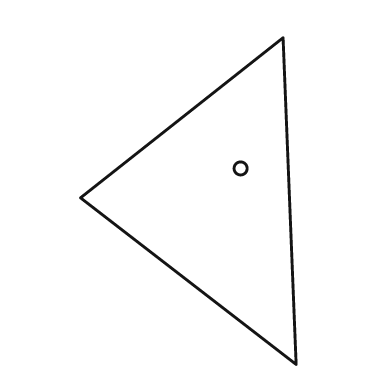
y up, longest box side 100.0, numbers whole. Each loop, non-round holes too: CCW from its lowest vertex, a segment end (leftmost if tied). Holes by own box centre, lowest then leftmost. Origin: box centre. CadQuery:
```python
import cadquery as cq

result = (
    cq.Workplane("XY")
    .moveTo(33.0, -50.0)
    .lineTo(29.0, 50.0)
    .lineTo(-33.0, 1.0)
    .close()
    .moveTo(16.0, 10.0)
    .circle(2.0)
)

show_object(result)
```